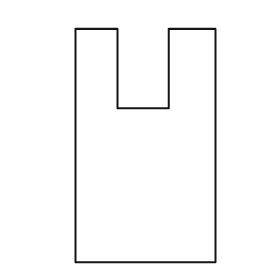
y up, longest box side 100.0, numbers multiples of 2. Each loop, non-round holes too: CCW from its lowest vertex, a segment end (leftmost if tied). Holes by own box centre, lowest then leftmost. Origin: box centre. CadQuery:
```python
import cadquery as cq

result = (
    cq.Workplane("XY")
    .moveTo(-30.0, -50.0)
    .lineTo(30.0, -50.0)
    .lineTo(30.0, 50.0)
    .lineTo(10.0, 50.0)
    .lineTo(10.0, 16.0)
    .lineTo(-12.0, 16.0)
    .lineTo(-12.0, 50.0)
    .lineTo(-30.0, 50.0)
    .close()
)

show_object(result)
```